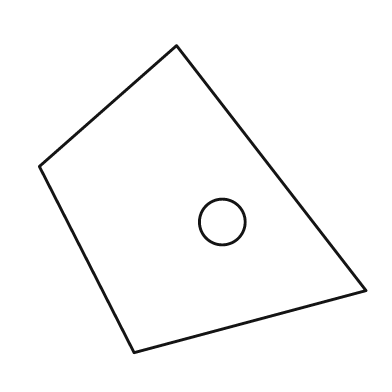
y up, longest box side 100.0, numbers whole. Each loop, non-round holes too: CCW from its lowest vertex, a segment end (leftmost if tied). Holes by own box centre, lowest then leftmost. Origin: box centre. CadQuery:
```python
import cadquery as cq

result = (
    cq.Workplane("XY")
    .moveTo(-21.0, -47.0)
    .lineTo(50.0, -28.0)
    .lineTo(-8.0, 47.0)
    .lineTo(-50.0, 10.0)
    .close()
    .moveTo(6.0, -7.0)
    .circle(7.0)
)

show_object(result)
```